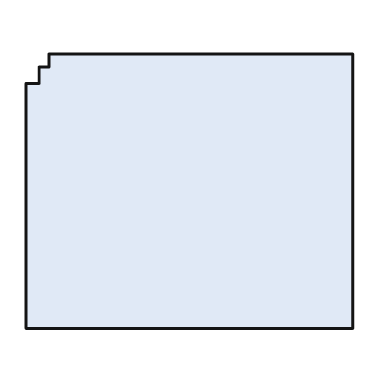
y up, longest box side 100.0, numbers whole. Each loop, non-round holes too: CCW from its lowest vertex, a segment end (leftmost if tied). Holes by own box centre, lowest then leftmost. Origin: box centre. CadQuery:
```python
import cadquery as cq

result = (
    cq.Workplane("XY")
    .moveTo(-50.0, -42.0)
    .lineTo(50.0, -42.0)
    .lineTo(50.0, 42.0)
    .lineTo(-43.0, 42.0)
    .lineTo(-43.0, 38.0)
    .lineTo(-46.0, 38.0)
    .lineTo(-46.0, 33.0)
    .lineTo(-50.0, 33.0)
    .close()
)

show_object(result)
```